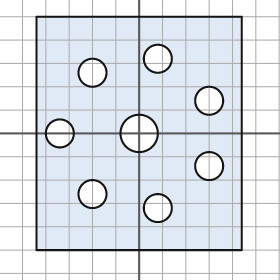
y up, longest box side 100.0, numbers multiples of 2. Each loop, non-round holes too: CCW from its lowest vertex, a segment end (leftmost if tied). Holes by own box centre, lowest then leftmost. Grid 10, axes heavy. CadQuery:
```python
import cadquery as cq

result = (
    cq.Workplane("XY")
    .moveTo(-44.0, -50.0)
    .lineTo(44.0, -50.0)
    .lineTo(44.0, 50.0)
    .lineTo(-44.0, 50.0)
    .close()
    .moveTo(8.0, -32.0)
    .circle(6.0)
    .moveTo(-20.0, -26.0)
    .circle(6.0)
    .moveTo(30.0, -14.0)
    .circle(6.0)
    .moveTo(-34.0, 0.0)
    .circle(6.0)
    .moveTo(0.0, 0.0)
    .circle(8.0)
    .moveTo(30.0, 14.0)
    .circle(6.0)
    .moveTo(-20.0, 26.0)
    .circle(6.0)
    .moveTo(8.0, 32.0)
    .circle(6.0)
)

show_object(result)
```